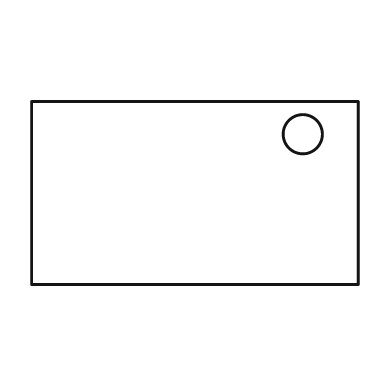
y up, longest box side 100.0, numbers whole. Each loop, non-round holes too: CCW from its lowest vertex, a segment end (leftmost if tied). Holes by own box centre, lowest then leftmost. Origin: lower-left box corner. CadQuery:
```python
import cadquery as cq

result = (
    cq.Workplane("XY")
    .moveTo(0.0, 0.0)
    .lineTo(100.0, 0.0)
    .lineTo(100.0, 56.0)
    .lineTo(0.0, 56.0)
    .close()
    .moveTo(83.0, 46.0)
    .circle(6.0)
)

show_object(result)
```